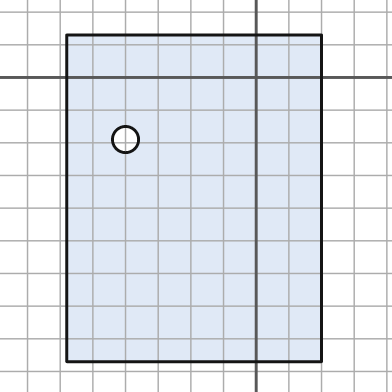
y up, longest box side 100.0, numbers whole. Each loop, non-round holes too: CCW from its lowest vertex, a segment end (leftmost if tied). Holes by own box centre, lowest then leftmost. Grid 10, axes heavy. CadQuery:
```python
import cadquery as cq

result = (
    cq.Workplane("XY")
    .moveTo(-58.0, -87.0)
    .lineTo(20.0, -87.0)
    .lineTo(20.0, 13.0)
    .lineTo(-58.0, 13.0)
    .close()
    .moveTo(-40.0, -19.0)
    .circle(4.0)
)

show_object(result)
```